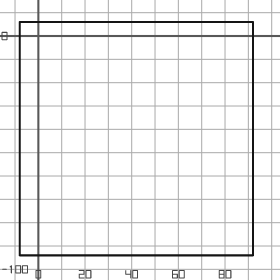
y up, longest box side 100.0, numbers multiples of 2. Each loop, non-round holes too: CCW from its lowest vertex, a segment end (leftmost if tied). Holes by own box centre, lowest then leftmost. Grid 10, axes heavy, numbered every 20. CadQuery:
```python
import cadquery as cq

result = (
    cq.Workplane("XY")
    .moveTo(-8.0, -94.0)
    .lineTo(92.0, -94.0)
    .lineTo(92.0, 6.0)
    .lineTo(-8.0, 6.0)
    .close()
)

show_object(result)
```